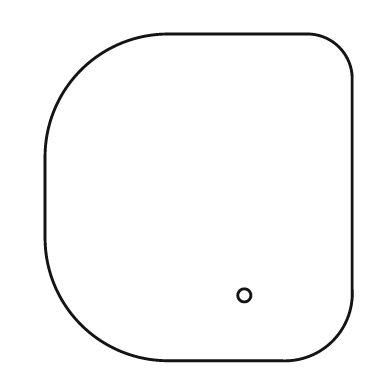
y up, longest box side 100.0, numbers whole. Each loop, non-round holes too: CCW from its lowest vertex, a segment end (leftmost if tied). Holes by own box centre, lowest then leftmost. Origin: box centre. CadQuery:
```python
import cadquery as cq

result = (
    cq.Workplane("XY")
    .moveTo(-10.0, -50.0)
    .lineTo(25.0, -50.0)
    .threePointArc((41.0, -44.0), (47.0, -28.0))
    .lineTo(47.0, 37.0)
    .threePointArc((43.0, 46.0), (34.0, 50.0))
    .lineTo(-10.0, 50.0)
    .threePointArc((-36.0, 39.0), (-47.0, 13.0))
    .lineTo(-47.0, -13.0)
    .threePointArc((-36.0, -39.0), (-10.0, -50.0))
    .close()
    .moveTo(14.0, -30.0)
    .circle(2.0)
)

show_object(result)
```